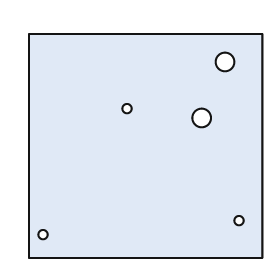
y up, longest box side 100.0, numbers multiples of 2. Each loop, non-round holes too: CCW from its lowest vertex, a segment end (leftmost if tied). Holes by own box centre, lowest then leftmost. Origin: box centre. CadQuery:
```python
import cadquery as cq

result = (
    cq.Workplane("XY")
    .moveTo(-50.0, -48.0)
    .lineTo(50.0, -48.0)
    .lineTo(50.0, 48.0)
    .lineTo(-50.0, 48.0)
    .close()
    .moveTo(-44.0, -38.0)
    .circle(2.0)
    .moveTo(40.0, -32.0)
    .circle(2.0)
    .moveTo(24.0, 12.0)
    .circle(4.0)
    .moveTo(-8.0, 16.0)
    .circle(2.0)
    .moveTo(34.0, 36.0)
    .circle(4.0)
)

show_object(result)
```